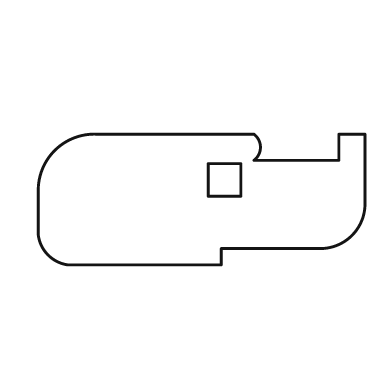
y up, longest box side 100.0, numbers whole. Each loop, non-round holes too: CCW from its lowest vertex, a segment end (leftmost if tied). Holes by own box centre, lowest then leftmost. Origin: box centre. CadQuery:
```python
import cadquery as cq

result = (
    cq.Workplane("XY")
    .moveTo(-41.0, -20.0)
    .lineTo(6.0, -20.0)
    .lineTo(6.0, -15.0)
    .lineTo(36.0, -15.0)
    .threePointArc((46.0, -11.0), (50.0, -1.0))
    .lineTo(50.0, 20.0)
    .lineTo(42.0, 20.0)
    .lineTo(42.0, 12.0)
    .lineTo(16.0, 12.0)
    .threePointArc((18.0, 16.0), (16.0, 20.0))
    .lineTo(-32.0, 20.0)
    .threePointArc((-45.0, 15.0), (-50.0, 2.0))
    .lineTo(-50.0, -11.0)
    .threePointArc((-47.0, -17.0), (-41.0, -20.0))
    .close()
    .moveTo(2.0, 1.0)
    .lineTo(12.0, 1.0)
    .lineTo(12.0, 11.0)
    .lineTo(2.0, 11.0)
    .close()
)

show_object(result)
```